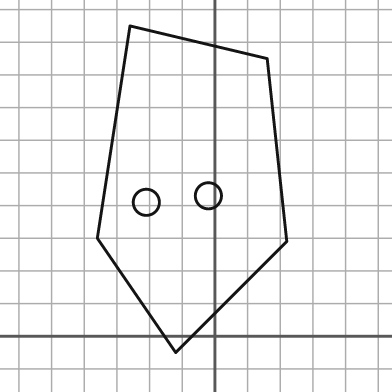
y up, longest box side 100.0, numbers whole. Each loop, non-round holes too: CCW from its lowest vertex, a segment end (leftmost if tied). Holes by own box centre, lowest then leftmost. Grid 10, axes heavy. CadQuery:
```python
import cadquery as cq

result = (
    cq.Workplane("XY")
    .moveTo(-12.0, -5.0)
    .lineTo(22.0, 29.0)
    .lineTo(16.0, 85.0)
    .lineTo(-26.0, 95.0)
    .lineTo(-36.0, 30.0)
    .close()
    .moveTo(-21.0, 41.0)
    .circle(4.0)
    .moveTo(-2.0, 43.0)
    .circle(4.0)
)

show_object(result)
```